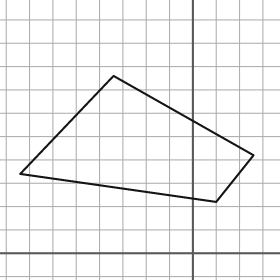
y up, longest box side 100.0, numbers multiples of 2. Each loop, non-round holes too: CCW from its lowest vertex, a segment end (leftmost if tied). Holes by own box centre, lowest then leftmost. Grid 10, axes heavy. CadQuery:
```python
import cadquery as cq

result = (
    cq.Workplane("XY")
    .moveTo(10.0, 22.0)
    .lineTo(26.0, 42.0)
    .lineTo(-34.0, 76.0)
    .lineTo(-74.0, 34.0)
    .close()
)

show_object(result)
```